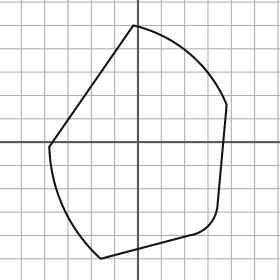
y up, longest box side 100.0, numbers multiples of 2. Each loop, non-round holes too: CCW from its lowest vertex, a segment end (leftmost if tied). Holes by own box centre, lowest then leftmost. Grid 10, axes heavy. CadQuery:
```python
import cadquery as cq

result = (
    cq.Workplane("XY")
    .moveTo(-16.0, -50.0)
    .lineTo(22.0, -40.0)
    .threePointArc((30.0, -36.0), (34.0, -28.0))
    .lineTo(38.0, 16.0)
    .threePointArc((22.0, 38.0), (-2.0, 50.0))
    .lineTo(-38.0, -2.0)
    .threePointArc((-32.0, -28.0), (-16.0, -50.0))
    .close()
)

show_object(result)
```